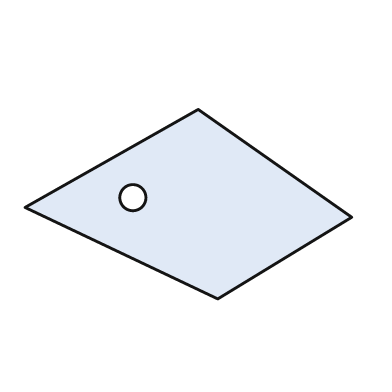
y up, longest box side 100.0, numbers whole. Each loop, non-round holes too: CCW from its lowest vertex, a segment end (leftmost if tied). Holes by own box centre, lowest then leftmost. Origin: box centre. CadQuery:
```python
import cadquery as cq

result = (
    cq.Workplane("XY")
    .moveTo(9.0, -29.0)
    .lineTo(50.0, -4.0)
    .lineTo(3.0, 29.0)
    .lineTo(-50.0, -1.0)
    .close()
    .moveTo(-17.0, 2.0)
    .circle(4.0)
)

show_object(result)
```